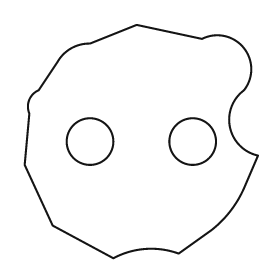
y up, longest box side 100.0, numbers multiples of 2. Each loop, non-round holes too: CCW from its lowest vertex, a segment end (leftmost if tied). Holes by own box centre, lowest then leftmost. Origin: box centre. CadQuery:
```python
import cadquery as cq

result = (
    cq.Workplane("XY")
    .moveTo(-12.0, -50.0)
    .threePointArc((2.0, -46.0), (16.0, -48.0))
    .lineTo(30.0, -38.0)
    .threePointArc((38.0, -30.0), (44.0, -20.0))
    .lineTo(50.0, -6.0)
    .threePointArc((38.0, 6.0), (44.0, 22.0))
    .threePointArc((44.0, 40.0), (26.0, 44.0))
    .lineTo(-2.0, 50.0)
    .lineTo(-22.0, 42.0)
    .threePointArc((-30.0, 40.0), (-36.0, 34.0))
    .lineTo(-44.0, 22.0)
    .threePointArc((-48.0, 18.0), (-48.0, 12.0))
    .lineTo(-50.0, -10.0)
    .lineTo(-38.0, -36.0)
    .close()
    .moveTo(-22.0, 0.0)
    .circle(10.0)
    .moveTo(22.0, 0.0)
    .circle(10.0)
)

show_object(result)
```